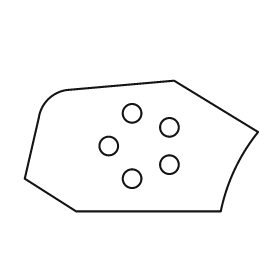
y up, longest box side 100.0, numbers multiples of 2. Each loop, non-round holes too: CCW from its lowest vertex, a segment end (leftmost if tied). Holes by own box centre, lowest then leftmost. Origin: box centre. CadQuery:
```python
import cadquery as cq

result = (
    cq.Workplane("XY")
    .moveTo(-28.0, -28.0)
    .lineTo(34.0, -28.0)
    .threePointArc((40.0, -10.0), (50.0, 6.0))
    .lineTo(14.0, 28.0)
    .lineTo(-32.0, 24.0)
    .threePointArc((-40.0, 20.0), (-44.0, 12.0))
    .lineTo(-50.0, -14.0)
    .close()
    .moveTo(-4.0, -14.0)
    .circle(4.0)
    .moveTo(12.0, -8.0)
    .circle(4.0)
    .moveTo(-14.0, 0.0)
    .circle(4.0)
    .moveTo(12.0, 8.0)
    .circle(4.0)
    .moveTo(-4.0, 14.0)
    .circle(4.0)
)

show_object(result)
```